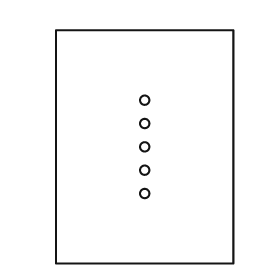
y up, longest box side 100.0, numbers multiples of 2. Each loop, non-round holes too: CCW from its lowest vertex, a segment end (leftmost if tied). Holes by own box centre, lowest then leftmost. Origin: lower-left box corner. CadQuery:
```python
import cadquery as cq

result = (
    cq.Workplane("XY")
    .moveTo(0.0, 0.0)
    .lineTo(76.0, 0.0)
    .lineTo(76.0, 100.0)
    .lineTo(0.0, 100.0)
    .close()
    .moveTo(38.0, 30.0)
    .circle(2.0)
    .moveTo(38.0, 40.0)
    .circle(2.0)
    .moveTo(38.0, 50.0)
    .circle(2.0)
    .moveTo(38.0, 60.0)
    .circle(2.0)
    .moveTo(38.0, 70.0)
    .circle(2.0)
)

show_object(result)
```